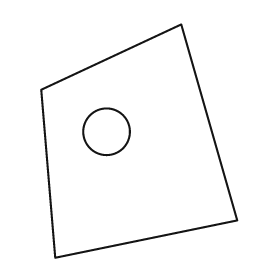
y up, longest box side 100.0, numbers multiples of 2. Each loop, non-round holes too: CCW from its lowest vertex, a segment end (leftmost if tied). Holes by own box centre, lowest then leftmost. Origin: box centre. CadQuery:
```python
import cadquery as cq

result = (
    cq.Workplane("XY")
    .moveTo(-36.0, -50.0)
    .lineTo(42.0, -34.0)
    .lineTo(18.0, 50.0)
    .lineTo(-42.0, 22.0)
    .close()
    .moveTo(-14.0, 4.0)
    .circle(10.0)
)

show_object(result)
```